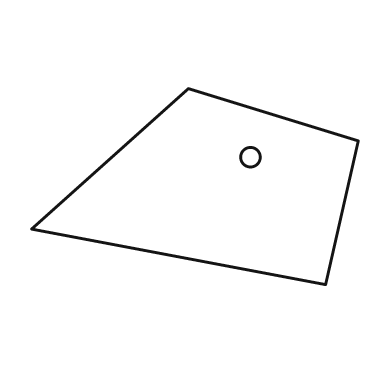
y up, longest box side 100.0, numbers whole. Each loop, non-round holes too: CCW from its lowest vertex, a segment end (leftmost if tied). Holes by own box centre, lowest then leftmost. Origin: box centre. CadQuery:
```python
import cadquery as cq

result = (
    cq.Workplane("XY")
    .moveTo(40.0, -30.0)
    .lineTo(50.0, 14.0)
    .lineTo(-2.0, 30.0)
    .lineTo(-50.0, -13.0)
    .close()
    .moveTo(17.0, 9.0)
    .circle(3.0)
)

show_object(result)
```